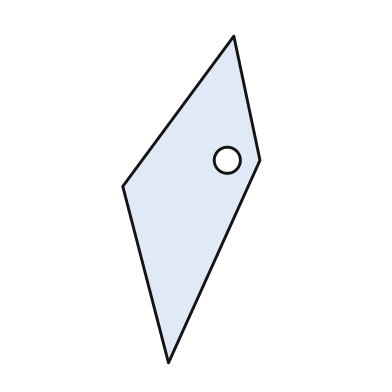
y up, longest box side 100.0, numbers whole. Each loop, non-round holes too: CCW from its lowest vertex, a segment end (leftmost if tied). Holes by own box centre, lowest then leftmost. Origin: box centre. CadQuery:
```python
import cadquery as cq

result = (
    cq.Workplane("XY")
    .moveTo(-7.0, -50.0)
    .lineTo(21.0, 12.0)
    .lineTo(13.0, 50.0)
    .lineTo(-21.0, 4.0)
    .close()
    .moveTo(11.0, 12.0)
    .circle(4.0)
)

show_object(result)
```